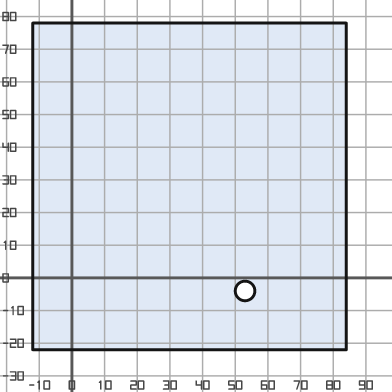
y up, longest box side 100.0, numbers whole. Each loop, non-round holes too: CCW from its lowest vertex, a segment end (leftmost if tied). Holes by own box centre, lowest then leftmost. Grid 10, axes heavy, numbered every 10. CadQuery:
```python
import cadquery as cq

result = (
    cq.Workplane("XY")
    .moveTo(-12.0, -22.0)
    .lineTo(84.0, -22.0)
    .lineTo(84.0, 78.0)
    .lineTo(-12.0, 78.0)
    .close()
    .moveTo(53.0, -4.0)
    .circle(3.0)
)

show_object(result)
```